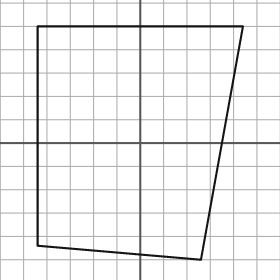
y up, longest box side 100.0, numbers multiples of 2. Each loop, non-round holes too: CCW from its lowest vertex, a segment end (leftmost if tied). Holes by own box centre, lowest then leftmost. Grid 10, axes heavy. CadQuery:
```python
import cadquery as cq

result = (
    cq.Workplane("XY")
    .moveTo(26.0, -50.0)
    .lineTo(44.0, 50.0)
    .lineTo(-44.0, 50.0)
    .lineTo(-44.0, -44.0)
    .close()
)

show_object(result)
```